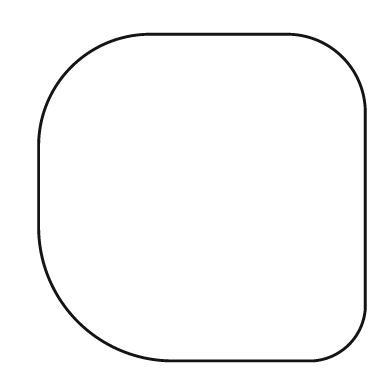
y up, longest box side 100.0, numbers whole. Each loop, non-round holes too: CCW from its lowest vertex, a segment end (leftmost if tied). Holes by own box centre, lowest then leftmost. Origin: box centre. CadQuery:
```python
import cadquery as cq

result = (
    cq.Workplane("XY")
    .moveTo(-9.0, -50.0)
    .lineTo(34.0, -50.0)
    .threePointArc((45.0, -45.0), (50.0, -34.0))
    .lineTo(50.0, 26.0)
    .threePointArc((43.0, 43.0), (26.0, 50.0))
    .lineTo(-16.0, 50.0)
    .threePointArc((-40.0, 40.0), (-50.0, 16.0))
    .lineTo(-50.0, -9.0)
    .threePointArc((-38.0, -38.0), (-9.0, -50.0))
    .close()
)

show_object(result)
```